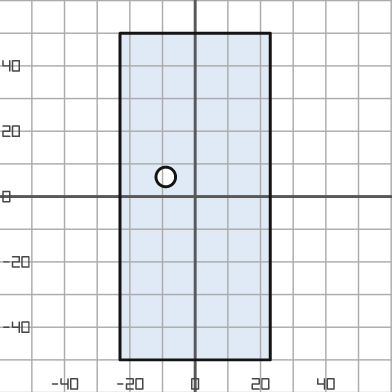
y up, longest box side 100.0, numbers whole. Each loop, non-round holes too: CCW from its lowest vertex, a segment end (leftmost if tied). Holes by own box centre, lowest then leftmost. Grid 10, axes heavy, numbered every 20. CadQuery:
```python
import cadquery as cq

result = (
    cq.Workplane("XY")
    .moveTo(-23.0, -50.0)
    .lineTo(23.0, -50.0)
    .lineTo(23.0, 50.0)
    .lineTo(-23.0, 50.0)
    .close()
    .moveTo(-9.0, 6.0)
    .circle(3.0)
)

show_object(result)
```